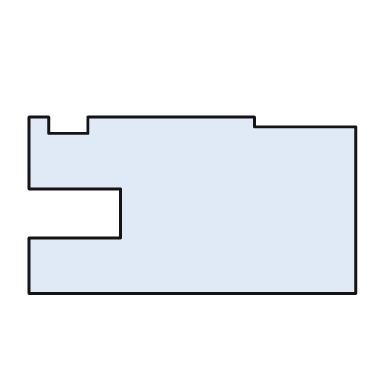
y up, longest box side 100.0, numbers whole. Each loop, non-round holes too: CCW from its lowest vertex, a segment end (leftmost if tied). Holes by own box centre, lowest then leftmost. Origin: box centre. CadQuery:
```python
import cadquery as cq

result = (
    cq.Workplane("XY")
    .moveTo(-50.0, -27.0)
    .lineTo(50.0, -27.0)
    .lineTo(50.0, 24.0)
    .lineTo(19.0, 24.0)
    .lineTo(19.0, 27.0)
    .lineTo(-32.0, 27.0)
    .lineTo(-32.0, 22.0)
    .lineTo(-44.0, 22.0)
    .lineTo(-44.0, 27.0)
    .lineTo(-50.0, 27.0)
    .lineTo(-50.0, 5.0)
    .lineTo(-22.0, 5.0)
    .lineTo(-22.0, -10.0)
    .lineTo(-50.0, -10.0)
    .close()
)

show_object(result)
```